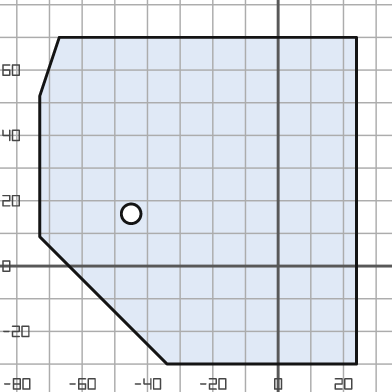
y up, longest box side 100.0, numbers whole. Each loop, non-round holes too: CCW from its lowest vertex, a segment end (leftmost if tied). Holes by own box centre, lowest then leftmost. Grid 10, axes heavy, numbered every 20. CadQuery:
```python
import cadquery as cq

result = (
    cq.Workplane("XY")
    .moveTo(-34.0, -30.0)
    .lineTo(24.0, -30.0)
    .lineTo(24.0, 70.0)
    .lineTo(-67.0, 70.0)
    .lineTo(-73.0, 52.0)
    .lineTo(-73.0, 9.0)
    .close()
    .moveTo(-45.0, 16.0)
    .circle(3.0)
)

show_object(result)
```